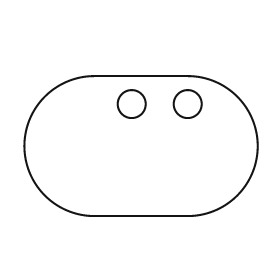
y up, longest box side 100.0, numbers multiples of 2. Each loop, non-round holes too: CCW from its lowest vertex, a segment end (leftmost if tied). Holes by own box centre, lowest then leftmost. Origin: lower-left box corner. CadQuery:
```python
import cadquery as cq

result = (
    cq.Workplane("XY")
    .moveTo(30.0, 0.0)
    .lineTo(70.0, 0.0)
    .threePointArc((100.0, 30.0), (70.0, 60.0))
    .lineTo(30.0, 60.0)
    .threePointArc((0.0, 30.0), (30.0, 0.0))
    .close()
    .moveTo(46.0, 48.0)
    .circle(6.0)
    .moveTo(70.0, 48.0)
    .circle(6.0)
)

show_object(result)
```